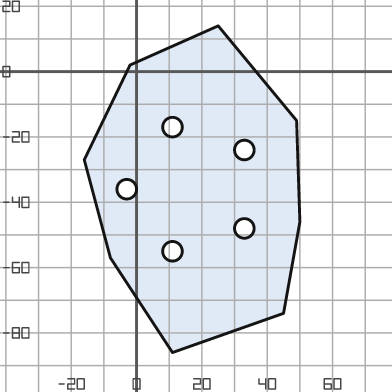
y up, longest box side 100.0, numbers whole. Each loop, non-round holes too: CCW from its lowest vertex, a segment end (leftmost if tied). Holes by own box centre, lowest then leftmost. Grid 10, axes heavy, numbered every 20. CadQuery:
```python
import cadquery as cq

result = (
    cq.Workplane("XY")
    .moveTo(11.0, -86.0)
    .lineTo(45.0, -74.0)
    .lineTo(50.0, -46.0)
    .lineTo(49.0, -15.0)
    .lineTo(25.0, 14.0)
    .lineTo(-2.0, 2.0)
    .lineTo(-16.0, -27.0)
    .lineTo(-8.0, -57.0)
    .close()
    .moveTo(11.0, -55.0)
    .circle(3.0)
    .moveTo(33.0, -48.0)
    .circle(3.0)
    .moveTo(-3.0, -36.0)
    .circle(3.0)
    .moveTo(33.0, -24.0)
    .circle(3.0)
    .moveTo(11.0, -17.0)
    .circle(3.0)
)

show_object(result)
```